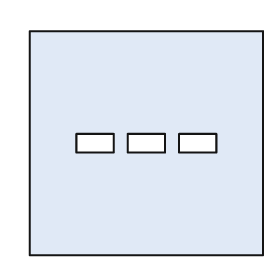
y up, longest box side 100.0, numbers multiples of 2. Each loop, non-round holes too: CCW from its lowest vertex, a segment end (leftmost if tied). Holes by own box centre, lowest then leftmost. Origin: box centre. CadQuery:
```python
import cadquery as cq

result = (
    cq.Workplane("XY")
    .moveTo(-50.0, -48.0)
    .lineTo(50.0, -48.0)
    .lineTo(50.0, 48.0)
    .lineTo(-50.0, 48.0)
    .close()
    .moveTo(-30.0, -4.0)
    .lineTo(-14.0, -4.0)
    .lineTo(-14.0, 4.0)
    .lineTo(-30.0, 4.0)
    .close()
    .moveTo(-8.0, -4.0)
    .lineTo(8.0, -4.0)
    .lineTo(8.0, 4.0)
    .lineTo(-8.0, 4.0)
    .close()
    .moveTo(14.0, -4.0)
    .lineTo(30.0, -4.0)
    .lineTo(30.0, 4.0)
    .lineTo(14.0, 4.0)
    .close()
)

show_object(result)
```